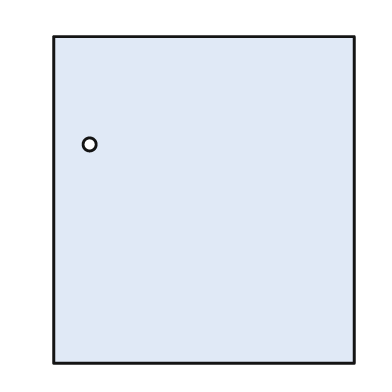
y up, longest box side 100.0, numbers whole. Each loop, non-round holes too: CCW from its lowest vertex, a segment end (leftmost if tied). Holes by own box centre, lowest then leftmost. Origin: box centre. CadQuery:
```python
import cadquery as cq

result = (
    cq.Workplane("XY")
    .moveTo(-46.0, -50.0)
    .lineTo(46.0, -50.0)
    .lineTo(46.0, 50.0)
    .lineTo(-46.0, 50.0)
    .close()
    .moveTo(-35.0, 17.0)
    .circle(2.0)
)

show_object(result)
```